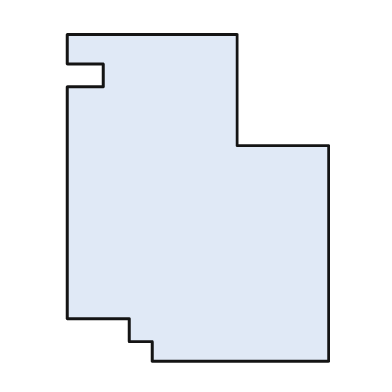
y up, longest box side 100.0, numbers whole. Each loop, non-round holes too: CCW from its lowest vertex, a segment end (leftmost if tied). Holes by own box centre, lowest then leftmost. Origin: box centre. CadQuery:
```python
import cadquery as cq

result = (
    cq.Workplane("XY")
    .moveTo(-14.0, -50.0)
    .lineTo(40.0, -50.0)
    .lineTo(40.0, 16.0)
    .lineTo(12.0, 16.0)
    .lineTo(12.0, 50.0)
    .lineTo(-40.0, 50.0)
    .lineTo(-40.0, 41.0)
    .lineTo(-29.0, 41.0)
    .lineTo(-29.0, 34.0)
    .lineTo(-40.0, 34.0)
    .lineTo(-40.0, -37.0)
    .lineTo(-21.0, -37.0)
    .lineTo(-21.0, -44.0)
    .lineTo(-14.0, -44.0)
    .close()
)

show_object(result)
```